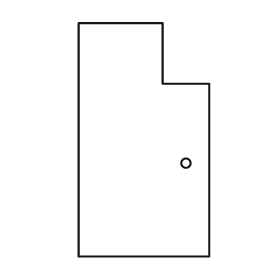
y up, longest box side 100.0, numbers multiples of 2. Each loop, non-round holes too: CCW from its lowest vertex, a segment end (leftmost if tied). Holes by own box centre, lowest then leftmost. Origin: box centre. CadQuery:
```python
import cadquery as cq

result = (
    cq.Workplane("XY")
    .moveTo(-28.0, -50.0)
    .lineTo(28.0, -50.0)
    .lineTo(28.0, 24.0)
    .lineTo(8.0, 24.0)
    .lineTo(8.0, 50.0)
    .lineTo(-28.0, 50.0)
    .close()
    .moveTo(18.0, -10.0)
    .circle(2.0)
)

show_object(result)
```